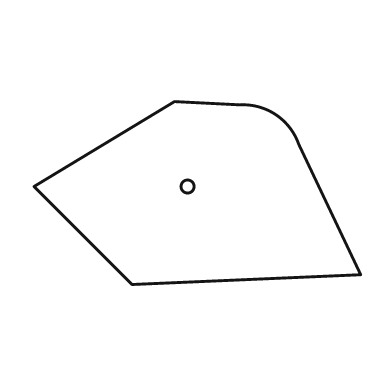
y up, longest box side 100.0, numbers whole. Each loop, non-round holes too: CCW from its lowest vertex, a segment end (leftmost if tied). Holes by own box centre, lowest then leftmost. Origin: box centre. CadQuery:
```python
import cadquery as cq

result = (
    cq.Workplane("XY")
    .moveTo(-20.0, -28.0)
    .lineTo(50.0, -25.0)
    .lineTo(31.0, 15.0)
    .threePointArc((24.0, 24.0), (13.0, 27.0))
    .lineTo(-7.0, 28.0)
    .lineTo(-50.0, 2.0)
    .close()
    .moveTo(-3.0, 2.0)
    .circle(2.0)
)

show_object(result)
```